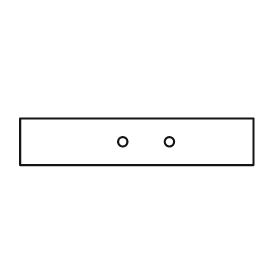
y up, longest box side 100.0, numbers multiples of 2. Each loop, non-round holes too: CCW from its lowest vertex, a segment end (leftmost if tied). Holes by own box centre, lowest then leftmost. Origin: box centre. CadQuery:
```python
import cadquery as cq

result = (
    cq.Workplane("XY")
    .moveTo(-50.0, -10.0)
    .lineTo(50.0, -10.0)
    .lineTo(50.0, 10.0)
    .lineTo(-50.0, 10.0)
    .close()
    .moveTo(-6.0, 0.0)
    .circle(2.0)
    .moveTo(14.0, 0.0)
    .circle(2.0)
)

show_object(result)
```